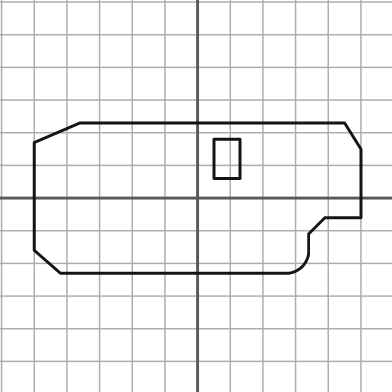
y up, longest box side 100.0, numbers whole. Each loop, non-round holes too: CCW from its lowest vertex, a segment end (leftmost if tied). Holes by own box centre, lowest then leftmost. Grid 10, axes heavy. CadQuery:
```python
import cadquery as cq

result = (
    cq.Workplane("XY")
    .moveTo(-42.0, -23.0)
    .lineTo(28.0, -23.0)
    .threePointArc((32.0, -21.0), (34.0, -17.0))
    .lineTo(34.0, -11.0)
    .lineTo(39.0, -6.0)
    .lineTo(50.0, -6.0)
    .lineTo(50.0, 15.0)
    .lineTo(45.0, 23.0)
    .lineTo(-36.0, 23.0)
    .lineTo(-50.0, 17.0)
    .lineTo(-50.0, -16.0)
    .close()
    .moveTo(5.0, 6.0)
    .lineTo(13.0, 6.0)
    .lineTo(13.0, 18.0)
    .lineTo(5.0, 18.0)
    .close()
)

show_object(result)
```